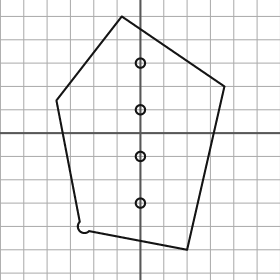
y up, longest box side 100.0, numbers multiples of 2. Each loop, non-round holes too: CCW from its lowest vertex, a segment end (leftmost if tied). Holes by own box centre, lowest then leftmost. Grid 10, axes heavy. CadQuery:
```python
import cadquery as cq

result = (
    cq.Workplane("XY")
    .moveTo(20.0, -50.0)
    .lineTo(36.0, 20.0)
    .lineTo(-8.0, 50.0)
    .lineTo(-36.0, 14.0)
    .lineTo(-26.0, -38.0)
    .threePointArc((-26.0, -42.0), (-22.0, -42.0))
    .close()
    .moveTo(0.0, -30.0)
    .circle(2.0)
    .moveTo(0.0, -10.0)
    .circle(2.0)
    .moveTo(0.0, 10.0)
    .circle(2.0)
    .moveTo(0.0, 30.0)
    .circle(2.0)
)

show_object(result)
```